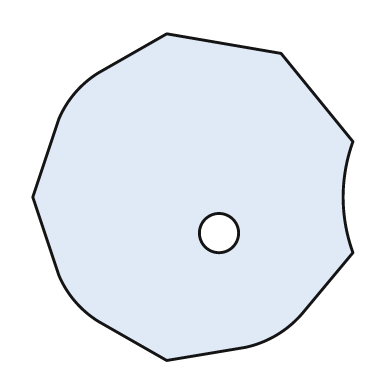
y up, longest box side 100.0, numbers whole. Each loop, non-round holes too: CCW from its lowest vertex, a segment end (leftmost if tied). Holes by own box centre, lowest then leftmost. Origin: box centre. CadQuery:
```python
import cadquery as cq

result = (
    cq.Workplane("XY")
    .moveTo(-8.0, -50.0)
    .lineTo(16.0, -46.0)
    .threePointArc((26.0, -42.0), (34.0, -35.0))
    .lineTo(49.0, -17.0)
    .threePointArc((46.0, 0.0), (49.0, 17.0))
    .lineTo(27.0, 44.0)
    .lineTo(-8.0, 50.0)
    .lineTo(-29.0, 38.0)
    .threePointArc((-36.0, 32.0), (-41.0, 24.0))
    .lineTo(-49.0, 0.0)
    .lineTo(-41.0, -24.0)
    .threePointArc((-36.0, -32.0), (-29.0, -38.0))
    .close()
    .moveTo(8.0, -11.0)
    .circle(6.0)
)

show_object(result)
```